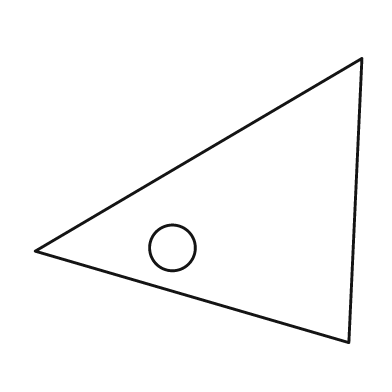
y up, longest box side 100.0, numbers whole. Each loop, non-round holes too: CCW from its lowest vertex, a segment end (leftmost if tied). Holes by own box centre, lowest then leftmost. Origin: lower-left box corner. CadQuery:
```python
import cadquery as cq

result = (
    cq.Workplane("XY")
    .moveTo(96.0, 0.0)
    .lineTo(100.0, 87.0)
    .lineTo(0.0, 28.0)
    .close()
    .moveTo(42.0, 29.0)
    .circle(7.0)
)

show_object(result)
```